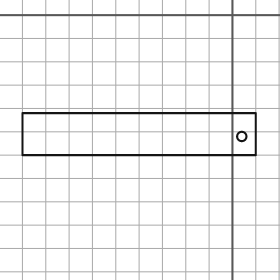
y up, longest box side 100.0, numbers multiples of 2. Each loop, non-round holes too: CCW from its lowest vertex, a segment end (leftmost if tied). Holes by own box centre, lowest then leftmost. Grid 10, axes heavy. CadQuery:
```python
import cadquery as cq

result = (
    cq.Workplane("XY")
    .moveTo(-90.0, -60.0)
    .lineTo(10.0, -60.0)
    .lineTo(10.0, -42.0)
    .lineTo(-90.0, -42.0)
    .close()
    .moveTo(4.0, -52.0)
    .circle(2.0)
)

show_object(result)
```